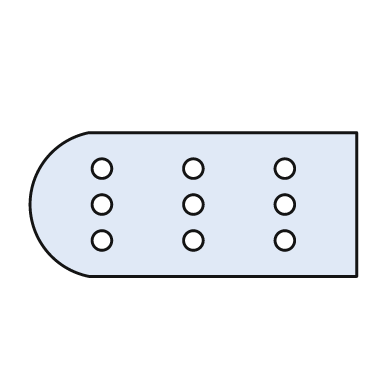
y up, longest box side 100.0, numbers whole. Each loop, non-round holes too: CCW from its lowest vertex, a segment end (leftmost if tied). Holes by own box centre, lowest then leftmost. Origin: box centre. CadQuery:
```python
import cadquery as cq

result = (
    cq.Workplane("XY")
    .moveTo(-32.0, -22.0)
    .lineTo(50.0, -22.0)
    .lineTo(50.0, 22.0)
    .lineTo(-32.0, 22.0)
    .threePointArc((-50.0, 0.0), (-32.0, -22.0))
    .close()
    .moveTo(-28.0, -11.0)
    .circle(3.0)
    .moveTo(0.0, -11.0)
    .circle(3.0)
    .moveTo(28.0, -11.0)
    .circle(3.0)
    .moveTo(-28.0, 0.0)
    .circle(3.0)
    .moveTo(0.0, 0.0)
    .circle(3.0)
    .moveTo(28.0, 0.0)
    .circle(3.0)
    .moveTo(-28.0, 11.0)
    .circle(3.0)
    .moveTo(0.0, 11.0)
    .circle(3.0)
    .moveTo(28.0, 11.0)
    .circle(3.0)
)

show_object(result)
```